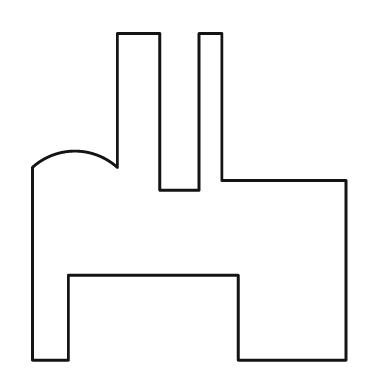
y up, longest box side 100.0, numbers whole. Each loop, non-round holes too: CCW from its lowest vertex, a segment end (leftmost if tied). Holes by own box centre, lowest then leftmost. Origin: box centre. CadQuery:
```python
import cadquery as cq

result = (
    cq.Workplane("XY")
    .moveTo(-48.0, -50.0)
    .lineTo(-37.0, -50.0)
    .lineTo(-37.0, -24.0)
    .lineTo(15.0, -24.0)
    .lineTo(15.0, -50.0)
    .lineTo(48.0, -50.0)
    .lineTo(48.0, 5.0)
    .lineTo(10.0, 5.0)
    .lineTo(10.0, 50.0)
    .lineTo(3.0, 50.0)
    .lineTo(3.0, 2.0)
    .lineTo(-9.0, 2.0)
    .lineTo(-9.0, 50.0)
    .lineTo(-22.0, 50.0)
    .lineTo(-22.0, 9.0)
    .threePointArc((-35.0, 14.0), (-48.0, 9.0))
    .close()
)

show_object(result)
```